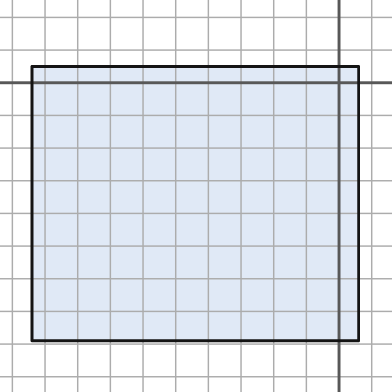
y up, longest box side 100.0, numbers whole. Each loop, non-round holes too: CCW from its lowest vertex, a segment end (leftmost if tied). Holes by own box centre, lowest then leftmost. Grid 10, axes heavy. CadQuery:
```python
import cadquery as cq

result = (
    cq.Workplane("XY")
    .moveTo(-94.0, -79.0)
    .lineTo(6.0, -79.0)
    .lineTo(6.0, 5.0)
    .lineTo(-94.0, 5.0)
    .close()
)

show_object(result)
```